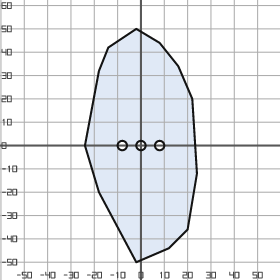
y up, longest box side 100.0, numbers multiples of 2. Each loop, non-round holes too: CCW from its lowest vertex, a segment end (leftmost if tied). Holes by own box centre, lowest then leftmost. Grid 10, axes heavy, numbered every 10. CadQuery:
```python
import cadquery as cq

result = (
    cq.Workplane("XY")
    .moveTo(-2.0, -50.0)
    .lineTo(12.0, -44.0)
    .lineTo(20.0, -36.0)
    .lineTo(24.0, -12.0)
    .lineTo(22.0, 20.0)
    .lineTo(16.0, 34.0)
    .lineTo(8.0, 44.0)
    .lineTo(-2.0, 50.0)
    .lineTo(-14.0, 42.0)
    .lineTo(-18.0, 32.0)
    .lineTo(-24.0, 0.0)
    .lineTo(-18.0, -20.0)
    .close()
    .moveTo(-8.0, 0.0)
    .circle(2.0)
    .moveTo(0.0, 0.0)
    .circle(2.0)
    .moveTo(8.0, 0.0)
    .circle(2.0)
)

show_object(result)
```